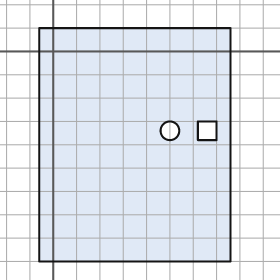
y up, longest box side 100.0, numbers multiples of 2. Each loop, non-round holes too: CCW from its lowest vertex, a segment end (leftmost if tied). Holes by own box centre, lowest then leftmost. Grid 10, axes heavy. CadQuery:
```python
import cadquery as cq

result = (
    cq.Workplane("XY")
    .moveTo(-6.0, -90.0)
    .lineTo(76.0, -90.0)
    .lineTo(76.0, 10.0)
    .lineTo(-6.0, 10.0)
    .close()
    .moveTo(50.0, -34.0)
    .circle(4.0)
    .moveTo(62.0, -38.0)
    .lineTo(70.0, -38.0)
    .lineTo(70.0, -30.0)
    .lineTo(62.0, -30.0)
    .close()
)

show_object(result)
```